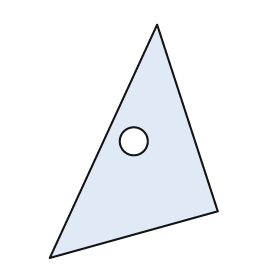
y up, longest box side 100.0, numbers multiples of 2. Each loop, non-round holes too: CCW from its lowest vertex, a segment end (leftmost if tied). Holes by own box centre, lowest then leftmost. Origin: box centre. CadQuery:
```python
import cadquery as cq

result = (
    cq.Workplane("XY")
    .moveTo(-36.0, -50.0)
    .lineTo(36.0, -30.0)
    .lineTo(10.0, 50.0)
    .close()
    .moveTo(0.0, 0.0)
    .circle(6.0)
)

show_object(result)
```